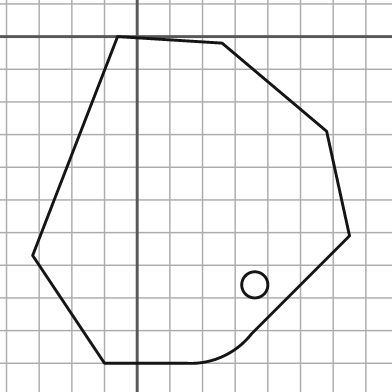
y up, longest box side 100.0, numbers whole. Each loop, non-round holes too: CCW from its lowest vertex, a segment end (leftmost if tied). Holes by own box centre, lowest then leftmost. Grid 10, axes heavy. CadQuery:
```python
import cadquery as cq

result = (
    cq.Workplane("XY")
    .moveTo(-10.0, -100.0)
    .lineTo(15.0, -100.0)
    .threePointArc((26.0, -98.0), (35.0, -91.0))
    .lineTo(65.0, -61.0)
    .lineTo(58.0, -29.0)
    .lineTo(26.0, -2.0)
    .lineTo(-6.0, 0.0)
    .lineTo(-32.0, -67.0)
    .close()
    .moveTo(36.0, -76.0)
    .circle(4.0)
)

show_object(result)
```